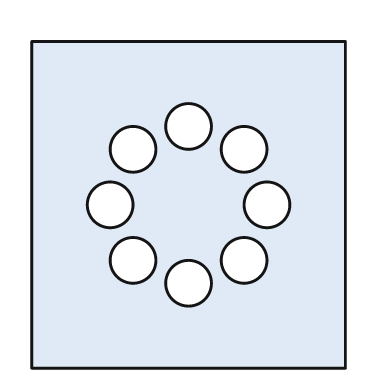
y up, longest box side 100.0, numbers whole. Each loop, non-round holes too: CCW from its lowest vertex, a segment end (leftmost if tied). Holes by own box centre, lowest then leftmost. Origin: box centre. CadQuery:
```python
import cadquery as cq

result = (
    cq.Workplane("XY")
    .moveTo(-48.0, -50.0)
    .lineTo(48.0, -50.0)
    .lineTo(48.0, 50.0)
    .lineTo(-48.0, 50.0)
    .close()
    .moveTo(0.0, -24.0)
    .circle(7.0)
    .moveTo(-17.0, -17.0)
    .circle(7.0)
    .moveTo(17.0, -17.0)
    .circle(7.0)
    .moveTo(-24.0, 0.0)
    .circle(7.0)
    .moveTo(24.0, 0.0)
    .circle(7.0)
    .moveTo(-17.0, 17.0)
    .circle(7.0)
    .moveTo(17.0, 17.0)
    .circle(7.0)
    .moveTo(0.0, 24.0)
    .circle(7.0)
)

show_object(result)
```